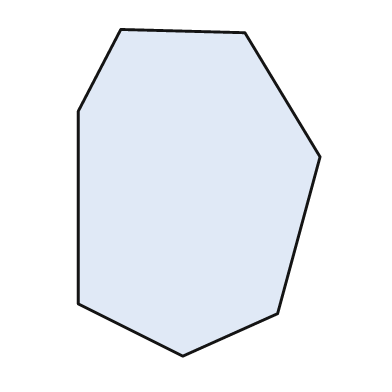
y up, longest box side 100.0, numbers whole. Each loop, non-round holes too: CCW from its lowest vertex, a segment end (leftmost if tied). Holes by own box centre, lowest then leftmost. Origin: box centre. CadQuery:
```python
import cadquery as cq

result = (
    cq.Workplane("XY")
    .moveTo(-5.0, -50.0)
    .lineTo(24.0, -37.0)
    .lineTo(37.0, 11.0)
    .lineTo(14.0, 49.0)
    .lineTo(-24.0, 50.0)
    .lineTo(-37.0, 25.0)
    .lineTo(-37.0, -34.0)
    .close()
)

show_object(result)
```